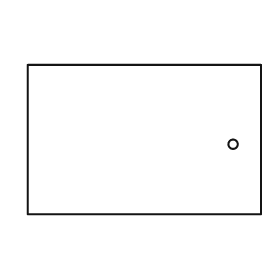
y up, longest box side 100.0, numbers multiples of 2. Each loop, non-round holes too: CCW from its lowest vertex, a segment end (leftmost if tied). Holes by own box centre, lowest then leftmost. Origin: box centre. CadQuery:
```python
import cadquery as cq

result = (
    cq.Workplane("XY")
    .moveTo(-50.0, -32.0)
    .lineTo(50.0, -32.0)
    .lineTo(50.0, 32.0)
    .lineTo(-50.0, 32.0)
    .close()
    .moveTo(38.0, -2.0)
    .circle(2.0)
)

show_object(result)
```